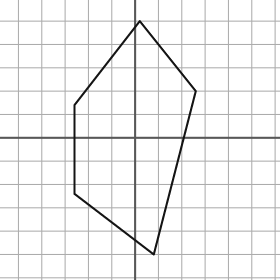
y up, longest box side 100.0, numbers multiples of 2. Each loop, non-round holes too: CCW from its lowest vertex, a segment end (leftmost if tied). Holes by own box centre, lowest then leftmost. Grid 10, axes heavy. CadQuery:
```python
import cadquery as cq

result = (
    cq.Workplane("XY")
    .moveTo(8.0, -50.0)
    .lineTo(26.0, 20.0)
    .lineTo(2.0, 50.0)
    .lineTo(-26.0, 14.0)
    .lineTo(-26.0, -24.0)
    .close()
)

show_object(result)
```